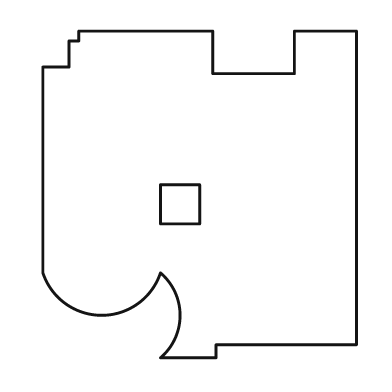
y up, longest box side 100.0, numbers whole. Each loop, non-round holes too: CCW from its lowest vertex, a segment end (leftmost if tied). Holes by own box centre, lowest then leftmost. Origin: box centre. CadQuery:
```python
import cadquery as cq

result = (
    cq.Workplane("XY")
    .moveTo(-12.0, -50.0)
    .lineTo(5.0, -50.0)
    .lineTo(5.0, -46.0)
    .lineTo(48.0, -46.0)
    .lineTo(48.0, 50.0)
    .lineTo(29.0, 50.0)
    .lineTo(29.0, 37.0)
    .lineTo(4.0, 37.0)
    .lineTo(4.0, 50.0)
    .lineTo(-37.0, 50.0)
    .lineTo(-37.0, 47.0)
    .lineTo(-40.0, 47.0)
    .lineTo(-40.0, 39.0)
    .lineTo(-48.0, 39.0)
    .lineTo(-48.0, -24.0)
    .threePointArc((-30.0, -37.0), (-12.0, -24.0))
    .threePointArc((-6.0, -37.0), (-12.0, -50.0))
    .close()
    .moveTo(-12.0, -9.0)
    .lineTo(0.0, -9.0)
    .lineTo(0.0, 3.0)
    .lineTo(-12.0, 3.0)
    .close()
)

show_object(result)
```